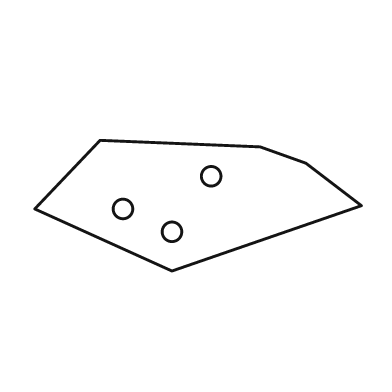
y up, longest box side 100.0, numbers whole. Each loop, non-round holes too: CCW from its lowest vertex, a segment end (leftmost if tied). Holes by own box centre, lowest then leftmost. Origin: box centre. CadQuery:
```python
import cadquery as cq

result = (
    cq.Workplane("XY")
    .moveTo(-8.0, -20.0)
    .lineTo(50.0, 0.0)
    .lineTo(33.0, 13.0)
    .lineTo(19.0, 18.0)
    .lineTo(-30.0, 20.0)
    .lineTo(-50.0, -1.0)
    .close()
    .moveTo(-8.0, -8.0)
    .circle(3.0)
    .moveTo(-23.0, -1.0)
    .circle(3.0)
    .moveTo(4.0, 9.0)
    .circle(3.0)
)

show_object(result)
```